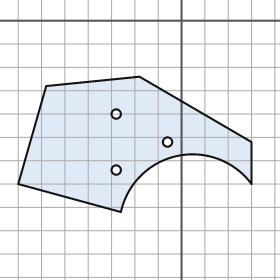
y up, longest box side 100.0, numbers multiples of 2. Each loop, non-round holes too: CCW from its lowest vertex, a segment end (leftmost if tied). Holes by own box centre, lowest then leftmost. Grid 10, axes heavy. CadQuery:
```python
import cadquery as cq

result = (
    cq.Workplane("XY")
    .moveTo(-26.0, -82.0)
    .threePointArc((-2.0, -58.0), (30.0, -70.0))
    .lineTo(30.0, -52.0)
    .lineTo(-18.0, -24.0)
    .lineTo(-58.0, -28.0)
    .lineTo(-70.0, -70.0)
    .close()
    .moveTo(-28.0, -64.0)
    .circle(2.0)
    .moveTo(-6.0, -52.0)
    .circle(2.0)
    .moveTo(-28.0, -40.0)
    .circle(2.0)
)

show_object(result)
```